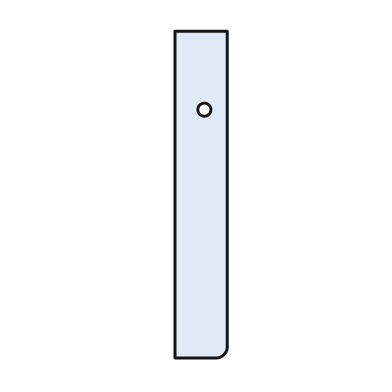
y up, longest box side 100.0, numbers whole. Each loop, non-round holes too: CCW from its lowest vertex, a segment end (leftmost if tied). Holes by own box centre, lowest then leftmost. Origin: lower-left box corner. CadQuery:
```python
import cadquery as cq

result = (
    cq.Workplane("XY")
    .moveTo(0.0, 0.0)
    .lineTo(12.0, 0.0)
    .threePointArc((15.0, 1.0), (16.0, 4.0))
    .lineTo(16.0, 100.0)
    .lineTo(0.0, 100.0)
    .close()
    .moveTo(9.0, 76.0)
    .circle(2.0)
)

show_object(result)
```